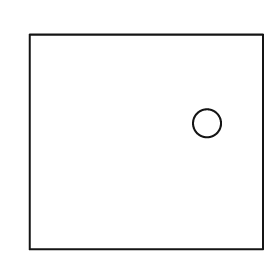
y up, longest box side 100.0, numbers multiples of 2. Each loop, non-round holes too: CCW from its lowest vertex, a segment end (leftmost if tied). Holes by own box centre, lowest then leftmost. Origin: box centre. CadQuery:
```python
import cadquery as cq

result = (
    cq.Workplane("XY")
    .moveTo(-50.0, -46.0)
    .lineTo(50.0, -46.0)
    .lineTo(50.0, 46.0)
    .lineTo(-50.0, 46.0)
    .close()
    .moveTo(26.0, 8.0)
    .circle(6.0)
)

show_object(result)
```